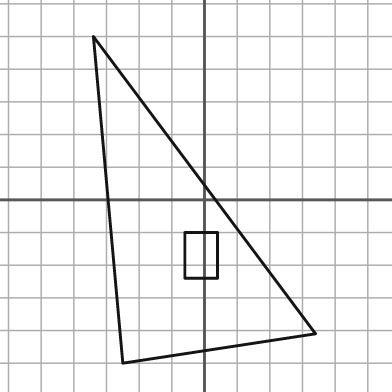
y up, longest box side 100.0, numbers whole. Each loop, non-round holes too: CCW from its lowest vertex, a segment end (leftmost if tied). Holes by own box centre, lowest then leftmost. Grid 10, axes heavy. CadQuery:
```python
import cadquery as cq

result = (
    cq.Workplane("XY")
    .moveTo(-25.0, -50.0)
    .lineTo(34.0, -41.0)
    .lineTo(-34.0, 50.0)
    .close()
    .moveTo(-6.0, -24.0)
    .lineTo(4.0, -24.0)
    .lineTo(4.0, -10.0)
    .lineTo(-6.0, -10.0)
    .close()
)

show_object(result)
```